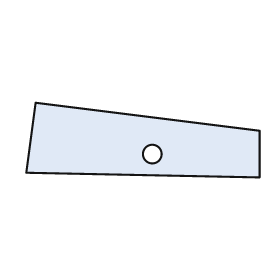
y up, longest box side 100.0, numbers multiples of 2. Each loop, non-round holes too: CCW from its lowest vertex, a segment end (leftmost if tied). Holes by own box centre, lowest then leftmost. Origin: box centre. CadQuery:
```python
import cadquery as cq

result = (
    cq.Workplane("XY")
    .moveTo(50.0, -16.0)
    .lineTo(50.0, 4.0)
    .lineTo(-46.0, 16.0)
    .lineTo(-50.0, -14.0)
    .close()
    .moveTo(4.0, -6.0)
    .circle(4.0)
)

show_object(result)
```